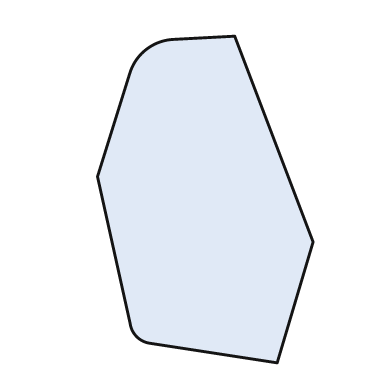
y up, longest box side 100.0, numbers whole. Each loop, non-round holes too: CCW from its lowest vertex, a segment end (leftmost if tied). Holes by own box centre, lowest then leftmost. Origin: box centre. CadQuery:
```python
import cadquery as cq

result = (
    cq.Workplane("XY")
    .moveTo(22.0, -50.0)
    .lineTo(33.0, -13.0)
    .lineTo(9.0, 50.0)
    .lineTo(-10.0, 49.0)
    .threePointArc((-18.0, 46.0), (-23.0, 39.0))
    .lineTo(-33.0, 7.0)
    .lineTo(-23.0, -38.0)
    .threePointArc((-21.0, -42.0), (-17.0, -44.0))
    .close()
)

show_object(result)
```